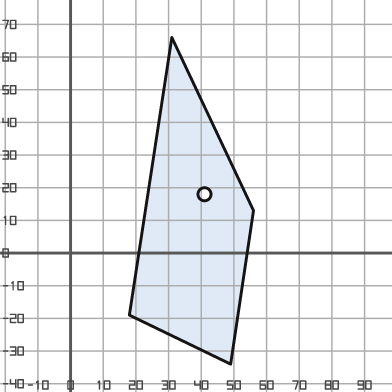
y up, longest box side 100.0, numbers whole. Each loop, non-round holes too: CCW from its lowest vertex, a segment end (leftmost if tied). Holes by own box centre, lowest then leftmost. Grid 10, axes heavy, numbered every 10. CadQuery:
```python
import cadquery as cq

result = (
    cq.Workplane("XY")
    .moveTo(49.0, -34.0)
    .lineTo(56.0, 13.0)
    .lineTo(31.0, 66.0)
    .lineTo(18.0, -19.0)
    .close()
    .moveTo(41.0, 18.0)
    .circle(2.0)
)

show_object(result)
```